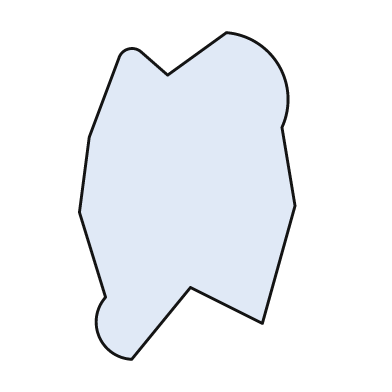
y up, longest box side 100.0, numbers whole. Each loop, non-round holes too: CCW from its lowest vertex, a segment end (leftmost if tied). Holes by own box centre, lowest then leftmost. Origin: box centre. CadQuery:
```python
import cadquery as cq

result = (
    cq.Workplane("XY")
    .moveTo(-17.0, -50.0)
    .lineTo(1.0, -28.0)
    .lineTo(23.0, -39.0)
    .lineTo(33.0, -3.0)
    .lineTo(29.0, 21.0)
    .threePointArc((28.0, 40.0), (12.0, 50.0))
    .lineTo(-6.0, 37.0)
    .lineTo(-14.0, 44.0)
    .threePointArc((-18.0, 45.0), (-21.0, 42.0))
    .lineTo(-30.0, 18.0)
    .lineTo(-33.0, -5.0)
    .lineTo(-25.0, -31.0)
    .threePointArc((-27.0, -43.0), (-17.0, -50.0))
    .close()
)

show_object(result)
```